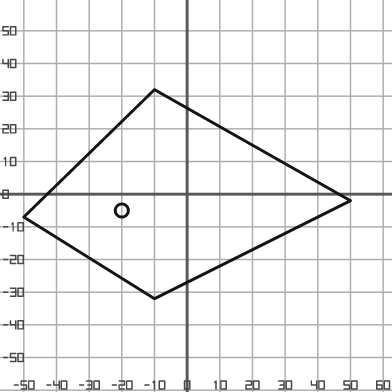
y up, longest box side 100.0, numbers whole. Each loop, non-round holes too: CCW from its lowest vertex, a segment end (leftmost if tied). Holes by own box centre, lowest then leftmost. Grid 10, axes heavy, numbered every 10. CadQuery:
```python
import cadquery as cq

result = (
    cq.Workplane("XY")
    .moveTo(-10.0, -32.0)
    .lineTo(50.0, -2.0)
    .lineTo(-10.0, 32.0)
    .lineTo(-50.0, -7.0)
    .close()
    .moveTo(-20.0, -5.0)
    .circle(2.0)
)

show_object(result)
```